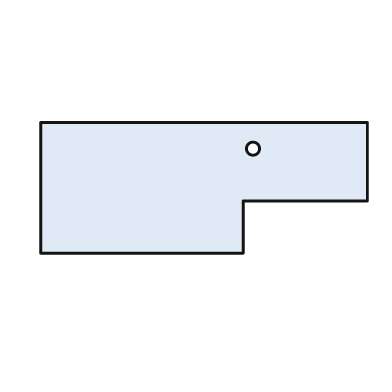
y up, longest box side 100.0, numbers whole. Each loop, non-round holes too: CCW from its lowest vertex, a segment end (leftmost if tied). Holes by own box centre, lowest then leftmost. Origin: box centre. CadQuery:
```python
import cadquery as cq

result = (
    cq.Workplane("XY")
    .moveTo(-50.0, -20.0)
    .lineTo(12.0, -20.0)
    .lineTo(12.0, -4.0)
    .lineTo(50.0, -4.0)
    .lineTo(50.0, 20.0)
    .lineTo(-50.0, 20.0)
    .close()
    .moveTo(15.0, 12.0)
    .circle(2.0)
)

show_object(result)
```